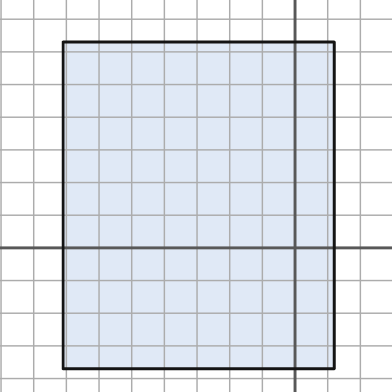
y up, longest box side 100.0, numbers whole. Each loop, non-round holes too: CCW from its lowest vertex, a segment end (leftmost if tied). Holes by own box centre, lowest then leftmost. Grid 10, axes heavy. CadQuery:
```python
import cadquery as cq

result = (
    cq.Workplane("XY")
    .moveTo(-71.0, -37.0)
    .lineTo(12.0, -37.0)
    .lineTo(12.0, 63.0)
    .lineTo(-71.0, 63.0)
    .close()
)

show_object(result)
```